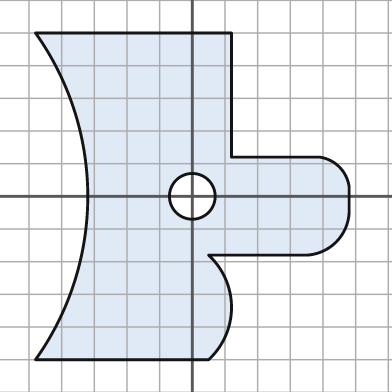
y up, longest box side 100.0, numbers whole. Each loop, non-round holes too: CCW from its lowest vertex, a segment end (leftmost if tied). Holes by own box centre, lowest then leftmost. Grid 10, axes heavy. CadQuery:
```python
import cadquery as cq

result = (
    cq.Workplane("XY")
    .moveTo(-48.0, -50.0)
    .lineTo(5.0, -50.0)
    .threePointArc((12.0, -34.0), (5.0, -18.0))
    .lineTo(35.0, -18.0)
    .threePointArc((44.0, -14.0), (48.0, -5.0))
    .lineTo(48.0, 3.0)
    .threePointArc((45.0, 9.0), (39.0, 12.0))
    .lineTo(12.0, 12.0)
    .lineTo(12.0, 50.0)
    .lineTo(-48.0, 50.0)
    .threePointArc((-32.0, 0.0), (-48.0, -50.0))
    .close()
    .moveTo(0.0, 0.0)
    .circle(7.0)
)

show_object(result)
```